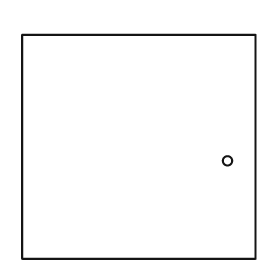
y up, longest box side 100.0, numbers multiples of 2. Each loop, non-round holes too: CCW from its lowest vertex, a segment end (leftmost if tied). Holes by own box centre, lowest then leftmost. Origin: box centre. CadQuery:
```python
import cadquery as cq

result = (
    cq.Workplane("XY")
    .moveTo(-50.0, -48.0)
    .lineTo(50.0, -48.0)
    .lineTo(50.0, 48.0)
    .lineTo(-50.0, 48.0)
    .close()
    .moveTo(38.0, -6.0)
    .circle(2.0)
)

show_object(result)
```